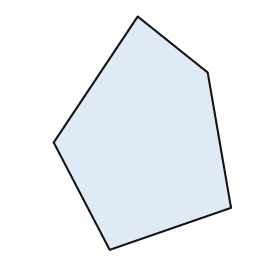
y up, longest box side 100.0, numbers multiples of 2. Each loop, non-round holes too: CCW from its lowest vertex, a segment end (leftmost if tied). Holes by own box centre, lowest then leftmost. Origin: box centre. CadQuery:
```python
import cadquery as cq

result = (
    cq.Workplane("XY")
    .moveTo(-14.0, -50.0)
    .lineTo(38.0, -32.0)
    .lineTo(28.0, 26.0)
    .lineTo(-2.0, 50.0)
    .lineTo(-38.0, -4.0)
    .close()
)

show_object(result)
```